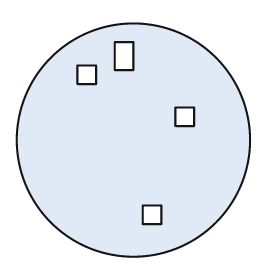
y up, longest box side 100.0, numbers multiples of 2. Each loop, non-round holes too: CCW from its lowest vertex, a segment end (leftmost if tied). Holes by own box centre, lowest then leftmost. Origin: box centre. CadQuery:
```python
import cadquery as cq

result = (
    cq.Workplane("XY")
    .moveTo(0.0, 0.0)
    .circle(50.0)
    .moveTo(4.0, -36.0)
    .lineTo(12.0, -36.0)
    .lineTo(12.0, -28.0)
    .lineTo(4.0, -28.0)
    .close()
    .moveTo(18.0, 6.0)
    .lineTo(26.0, 6.0)
    .lineTo(26.0, 14.0)
    .lineTo(18.0, 14.0)
    .close()
    .moveTo(-24.0, 24.0)
    .lineTo(-16.0, 24.0)
    .lineTo(-16.0, 32.0)
    .lineTo(-24.0, 32.0)
    .close()
    .moveTo(-8.0, 30.0)
    .lineTo(0.0, 30.0)
    .lineTo(0.0, 42.0)
    .lineTo(-8.0, 42.0)
    .close()
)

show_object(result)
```